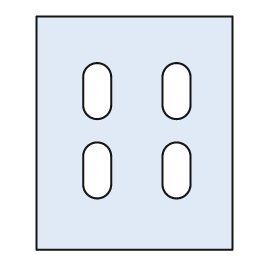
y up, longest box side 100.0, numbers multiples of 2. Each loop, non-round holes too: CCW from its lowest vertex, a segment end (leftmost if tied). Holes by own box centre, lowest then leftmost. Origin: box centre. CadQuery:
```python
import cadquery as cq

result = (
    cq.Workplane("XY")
    .moveTo(-42.0, -50.0)
    .lineTo(42.0, -50.0)
    .lineTo(42.0, 50.0)
    .lineTo(-42.0, 50.0)
    .close()
    .moveTo(-22.0, -22.0)
    .threePointArc((-16.0, -28.0), (-10.0, -22.0))
    .lineTo(-10.0, -10.0)
    .threePointArc((-16.0, -4.0), (-22.0, -10.0))
    .close()
    .moveTo(12.0, -22.0)
    .threePointArc((18.0, -28.0), (24.0, -22.0))
    .lineTo(24.0, -10.0)
    .threePointArc((18.0, -4.0), (12.0, -10.0))
    .close()
    .moveTo(-22.0, 12.0)
    .threePointArc((-16.0, 6.0), (-10.0, 12.0))
    .lineTo(-10.0, 24.0)
    .threePointArc((-16.0, 30.0), (-22.0, 24.0))
    .close()
    .moveTo(12.0, 12.0)
    .threePointArc((18.0, 6.0), (24.0, 12.0))
    .lineTo(24.0, 24.0)
    .threePointArc((18.0, 30.0), (12.0, 24.0))
    .close()
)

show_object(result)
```